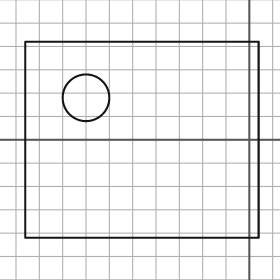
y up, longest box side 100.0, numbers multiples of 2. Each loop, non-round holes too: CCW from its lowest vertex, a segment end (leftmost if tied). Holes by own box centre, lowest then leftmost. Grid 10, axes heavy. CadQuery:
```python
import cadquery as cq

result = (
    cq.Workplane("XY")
    .moveTo(-96.0, -42.0)
    .lineTo(4.0, -42.0)
    .lineTo(4.0, 42.0)
    .lineTo(-96.0, 42.0)
    .close()
    .moveTo(-70.0, 18.0)
    .circle(10.0)
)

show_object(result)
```